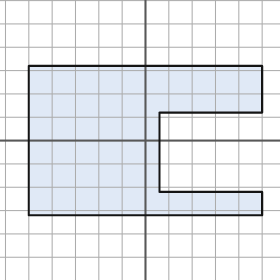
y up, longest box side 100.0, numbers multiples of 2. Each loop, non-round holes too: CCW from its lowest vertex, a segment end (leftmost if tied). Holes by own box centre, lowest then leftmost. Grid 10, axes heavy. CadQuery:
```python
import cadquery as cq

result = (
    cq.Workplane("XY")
    .moveTo(-50.0, -32.0)
    .lineTo(50.0, -32.0)
    .lineTo(50.0, -22.0)
    .lineTo(6.0, -22.0)
    .lineTo(6.0, 12.0)
    .lineTo(50.0, 12.0)
    .lineTo(50.0, 32.0)
    .lineTo(-50.0, 32.0)
    .close()
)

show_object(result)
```